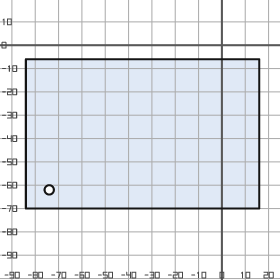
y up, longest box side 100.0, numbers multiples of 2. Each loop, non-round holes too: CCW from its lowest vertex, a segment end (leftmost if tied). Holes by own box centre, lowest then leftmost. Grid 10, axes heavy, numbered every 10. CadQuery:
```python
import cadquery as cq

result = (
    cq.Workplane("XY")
    .moveTo(-84.0, -70.0)
    .lineTo(16.0, -70.0)
    .lineTo(16.0, -6.0)
    .lineTo(-84.0, -6.0)
    .close()
    .moveTo(-74.0, -62.0)
    .circle(2.0)
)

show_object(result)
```